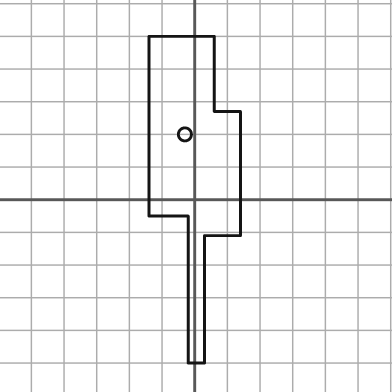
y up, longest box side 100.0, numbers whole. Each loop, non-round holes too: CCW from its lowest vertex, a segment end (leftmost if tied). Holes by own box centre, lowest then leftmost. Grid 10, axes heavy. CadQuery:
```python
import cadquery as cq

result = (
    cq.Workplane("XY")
    .moveTo(-2.0, -50.0)
    .lineTo(3.0, -50.0)
    .lineTo(3.0, -11.0)
    .lineTo(14.0, -11.0)
    .lineTo(14.0, 27.0)
    .lineTo(6.0, 27.0)
    .lineTo(6.0, 50.0)
    .lineTo(-14.0, 50.0)
    .lineTo(-14.0, -5.0)
    .lineTo(-2.0, -5.0)
    .close()
    .moveTo(-3.0, 20.0)
    .circle(2.0)
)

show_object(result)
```